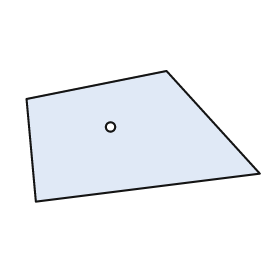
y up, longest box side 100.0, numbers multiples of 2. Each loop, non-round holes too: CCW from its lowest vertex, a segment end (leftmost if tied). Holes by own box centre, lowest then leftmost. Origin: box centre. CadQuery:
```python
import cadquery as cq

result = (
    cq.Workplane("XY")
    .moveTo(-46.0, -28.0)
    .lineTo(50.0, -16.0)
    .lineTo(10.0, 28.0)
    .lineTo(-50.0, 16.0)
    .close()
    .moveTo(-14.0, 4.0)
    .circle(2.0)
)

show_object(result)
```